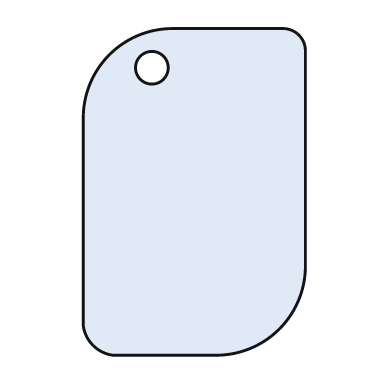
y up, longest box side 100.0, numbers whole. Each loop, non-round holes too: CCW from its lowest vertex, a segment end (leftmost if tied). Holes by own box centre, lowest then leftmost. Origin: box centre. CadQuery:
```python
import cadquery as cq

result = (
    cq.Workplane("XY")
    .moveTo(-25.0, -50.0)
    .lineTo(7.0, -50.0)
    .threePointArc((26.0, -42.0), (34.0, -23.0))
    .lineTo(34.0, 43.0)
    .threePointArc((32.0, 48.0), (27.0, 50.0))
    .lineTo(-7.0, 50.0)
    .threePointArc((-26.0, 42.0), (-34.0, 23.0))
    .lineTo(-34.0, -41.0)
    .threePointArc((-31.0, -47.0), (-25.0, -50.0))
    .close()
    .moveTo(-13.0, 38.0)
    .circle(5.0)
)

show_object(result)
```